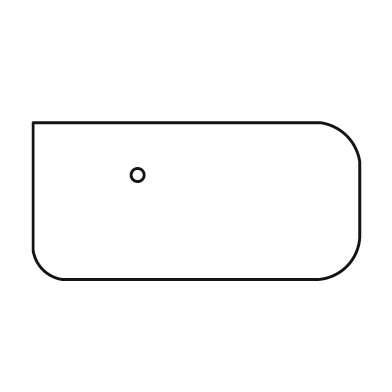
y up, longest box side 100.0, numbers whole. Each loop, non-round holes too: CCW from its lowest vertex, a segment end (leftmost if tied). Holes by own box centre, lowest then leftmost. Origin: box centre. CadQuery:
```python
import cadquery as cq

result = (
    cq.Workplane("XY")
    .moveTo(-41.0, -24.0)
    .lineTo(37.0, -24.0)
    .threePointArc((46.0, -20.0), (50.0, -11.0))
    .lineTo(50.0, 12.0)
    .threePointArc((46.0, 20.0), (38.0, 24.0))
    .lineTo(-50.0, 24.0)
    .lineTo(-50.0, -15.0)
    .threePointArc((-47.0, -21.0), (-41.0, -24.0))
    .close()
    .moveTo(-18.0, 8.0)
    .circle(2.0)
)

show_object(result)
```